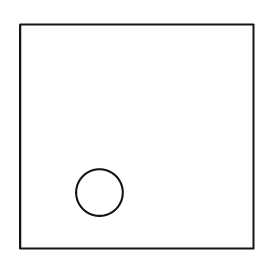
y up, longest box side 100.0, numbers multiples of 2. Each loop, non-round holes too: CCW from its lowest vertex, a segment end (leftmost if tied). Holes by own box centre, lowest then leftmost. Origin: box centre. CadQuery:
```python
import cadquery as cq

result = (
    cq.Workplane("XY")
    .moveTo(-50.0, -48.0)
    .lineTo(50.0, -48.0)
    .lineTo(50.0, 48.0)
    .lineTo(-50.0, 48.0)
    .close()
    .moveTo(-16.0, -24.0)
    .circle(10.0)
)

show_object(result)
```